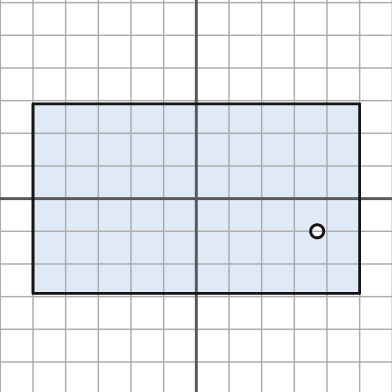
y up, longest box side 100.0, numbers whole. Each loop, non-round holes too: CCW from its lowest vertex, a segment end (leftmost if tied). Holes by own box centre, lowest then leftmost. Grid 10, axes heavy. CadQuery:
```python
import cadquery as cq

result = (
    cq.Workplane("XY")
    .moveTo(-50.0, -29.0)
    .lineTo(50.0, -29.0)
    .lineTo(50.0, 29.0)
    .lineTo(-50.0, 29.0)
    .close()
    .moveTo(37.0, -10.0)
    .circle(2.0)
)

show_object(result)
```